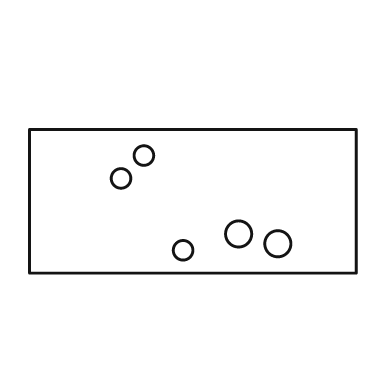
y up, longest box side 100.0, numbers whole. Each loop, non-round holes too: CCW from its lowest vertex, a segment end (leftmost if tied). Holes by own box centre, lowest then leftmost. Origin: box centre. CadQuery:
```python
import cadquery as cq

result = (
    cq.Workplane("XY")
    .moveTo(-50.0, -22.0)
    .lineTo(50.0, -22.0)
    .lineTo(50.0, 22.0)
    .lineTo(-50.0, 22.0)
    .close()
    .moveTo(-3.0, -15.0)
    .circle(3.0)
    .moveTo(26.0, -13.0)
    .circle(4.0)
    .moveTo(14.0, -10.0)
    .circle(4.0)
    .moveTo(-22.0, 7.0)
    .circle(3.0)
    .moveTo(-15.0, 14.0)
    .circle(3.0)
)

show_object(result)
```